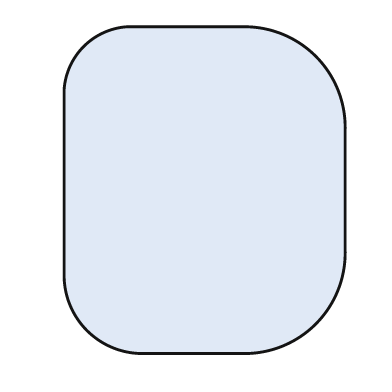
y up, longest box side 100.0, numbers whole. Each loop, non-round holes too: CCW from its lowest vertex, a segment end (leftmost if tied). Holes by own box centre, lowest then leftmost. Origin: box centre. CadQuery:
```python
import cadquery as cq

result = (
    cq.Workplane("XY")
    .moveTo(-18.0, -50.0)
    .lineTo(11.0, -50.0)
    .threePointArc((34.0, -41.0), (43.0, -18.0))
    .lineTo(43.0, 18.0)
    .threePointArc((34.0, 41.0), (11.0, 50.0))
    .lineTo(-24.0, 50.0)
    .threePointArc((-37.0, 44.0), (-43.0, 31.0))
    .lineTo(-43.0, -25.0)
    .threePointArc((-36.0, -43.0), (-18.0, -50.0))
    .close()
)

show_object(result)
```